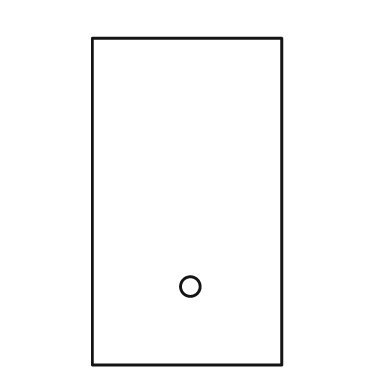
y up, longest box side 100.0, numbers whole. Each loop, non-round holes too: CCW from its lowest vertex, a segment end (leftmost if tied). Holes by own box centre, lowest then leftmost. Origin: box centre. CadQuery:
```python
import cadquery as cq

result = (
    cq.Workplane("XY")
    .moveTo(-29.0, -50.0)
    .lineTo(29.0, -50.0)
    .lineTo(29.0, 50.0)
    .lineTo(-29.0, 50.0)
    .close()
    .moveTo(1.0, -26.0)
    .circle(3.0)
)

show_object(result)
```